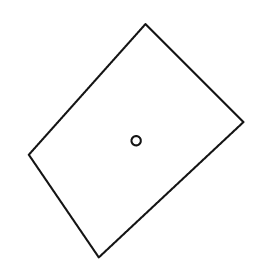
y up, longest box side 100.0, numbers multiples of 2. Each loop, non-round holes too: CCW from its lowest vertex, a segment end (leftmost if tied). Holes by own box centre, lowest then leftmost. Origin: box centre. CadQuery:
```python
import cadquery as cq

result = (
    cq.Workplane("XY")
    .moveTo(-16.0, -50.0)
    .lineTo(46.0, 8.0)
    .lineTo(4.0, 50.0)
    .lineTo(-46.0, -6.0)
    .close()
    .moveTo(0.0, 0.0)
    .circle(2.0)
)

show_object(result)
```